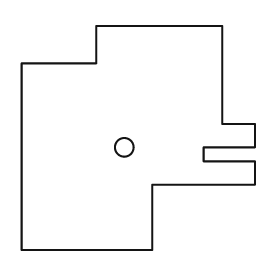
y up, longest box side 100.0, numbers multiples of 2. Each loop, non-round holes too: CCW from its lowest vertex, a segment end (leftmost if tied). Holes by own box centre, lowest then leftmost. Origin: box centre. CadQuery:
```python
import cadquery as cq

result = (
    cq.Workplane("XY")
    .moveTo(-50.0, -48.0)
    .lineTo(6.0, -48.0)
    .lineTo(6.0, -20.0)
    .lineTo(50.0, -20.0)
    .lineTo(50.0, -10.0)
    .lineTo(28.0, -10.0)
    .lineTo(28.0, -4.0)
    .lineTo(50.0, -4.0)
    .lineTo(50.0, 6.0)
    .lineTo(36.0, 6.0)
    .lineTo(36.0, 48.0)
    .lineTo(-18.0, 48.0)
    .lineTo(-18.0, 32.0)
    .lineTo(-50.0, 32.0)
    .close()
    .moveTo(-6.0, -4.0)
    .circle(4.0)
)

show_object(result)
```